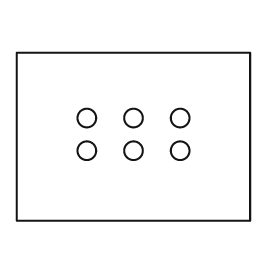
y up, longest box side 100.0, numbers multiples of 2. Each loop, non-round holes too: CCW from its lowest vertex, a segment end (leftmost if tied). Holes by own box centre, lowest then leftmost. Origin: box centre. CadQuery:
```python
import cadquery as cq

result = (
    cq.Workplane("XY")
    .moveTo(-50.0, -36.0)
    .lineTo(50.0, -36.0)
    .lineTo(50.0, 36.0)
    .lineTo(-50.0, 36.0)
    .close()
    .moveTo(-20.0, -6.0)
    .circle(4.0)
    .moveTo(0.0, -6.0)
    .circle(4.0)
    .moveTo(20.0, -6.0)
    .circle(4.0)
    .moveTo(-20.0, 8.0)
    .circle(4.0)
    .moveTo(0.0, 8.0)
    .circle(4.0)
    .moveTo(20.0, 8.0)
    .circle(4.0)
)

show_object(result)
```